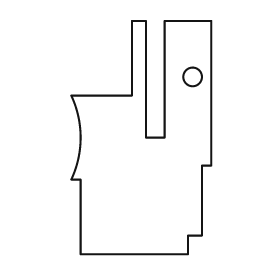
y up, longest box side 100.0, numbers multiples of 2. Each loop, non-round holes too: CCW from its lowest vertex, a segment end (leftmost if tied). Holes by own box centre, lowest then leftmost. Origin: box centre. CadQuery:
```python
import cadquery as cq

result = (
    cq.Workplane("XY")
    .moveTo(-26.0, -50.0)
    .lineTo(20.0, -50.0)
    .lineTo(20.0, -42.0)
    .lineTo(26.0, -42.0)
    .lineTo(26.0, -12.0)
    .lineTo(30.0, -12.0)
    .lineTo(30.0, 50.0)
    .lineTo(10.0, 50.0)
    .lineTo(10.0, 0.0)
    .lineTo(2.0, 0.0)
    .lineTo(2.0, 50.0)
    .lineTo(-4.0, 50.0)
    .lineTo(-4.0, 18.0)
    .lineTo(-30.0, 18.0)
    .threePointArc((-26.0, 0.0), (-30.0, -18.0))
    .lineTo(-26.0, -18.0)
    .close()
    .moveTo(22.0, 26.0)
    .circle(4.0)
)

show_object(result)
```